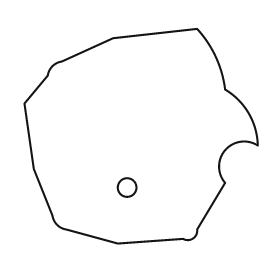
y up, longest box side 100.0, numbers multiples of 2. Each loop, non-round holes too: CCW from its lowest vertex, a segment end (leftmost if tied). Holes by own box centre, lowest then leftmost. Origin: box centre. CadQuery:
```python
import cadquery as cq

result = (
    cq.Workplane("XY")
    .moveTo(-10.0, -46.0)
    .lineTo(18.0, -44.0)
    .threePointArc((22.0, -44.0), (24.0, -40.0))
    .lineTo(36.0, -20.0)
    .threePointArc((36.0, -6.0), (50.0, -4.0))
    .threePointArc((46.0, 10.0), (36.0, 20.0))
    .threePointArc((32.0, 34.0), (24.0, 46.0))
    .lineTo(-12.0, 42.0)
    .lineTo(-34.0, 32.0)
    .threePointArc((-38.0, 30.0), (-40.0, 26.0))
    .lineTo(-50.0, 14.0)
    .lineTo(-46.0, -14.0)
    .lineTo(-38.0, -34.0)
    .threePointArc((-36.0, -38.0), (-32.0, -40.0))
    .close()
    .moveTo(-6.0, -22.0)
    .circle(4.0)
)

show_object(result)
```